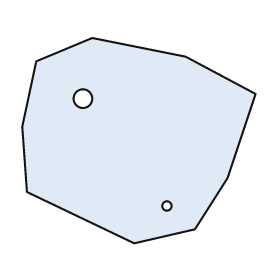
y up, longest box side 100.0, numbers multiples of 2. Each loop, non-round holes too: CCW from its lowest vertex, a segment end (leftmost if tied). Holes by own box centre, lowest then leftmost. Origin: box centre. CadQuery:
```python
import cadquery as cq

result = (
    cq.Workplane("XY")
    .moveTo(-2.0, -44.0)
    .lineTo(24.0, -38.0)
    .lineTo(38.0, -16.0)
    .lineTo(50.0, 20.0)
    .lineTo(20.0, 36.0)
    .lineTo(-20.0, 44.0)
    .lineTo(-44.0, 34.0)
    .lineTo(-50.0, 6.0)
    .lineTo(-48.0, -22.0)
    .close()
    .moveTo(12.0, -28.0)
    .circle(2.0)
    .moveTo(-24.0, 18.0)
    .circle(4.0)
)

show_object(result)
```